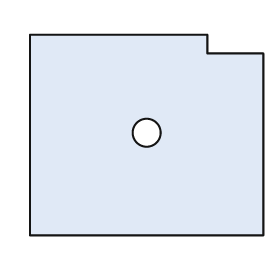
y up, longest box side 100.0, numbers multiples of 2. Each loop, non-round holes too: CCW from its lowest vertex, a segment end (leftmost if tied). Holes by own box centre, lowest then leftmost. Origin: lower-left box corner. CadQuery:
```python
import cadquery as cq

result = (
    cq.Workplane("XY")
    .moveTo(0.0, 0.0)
    .lineTo(100.0, 0.0)
    .lineTo(100.0, 78.0)
    .lineTo(76.0, 78.0)
    .lineTo(76.0, 86.0)
    .lineTo(0.0, 86.0)
    .close()
    .moveTo(50.0, 44.0)
    .circle(6.0)
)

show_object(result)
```